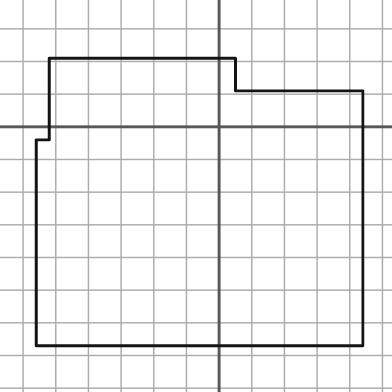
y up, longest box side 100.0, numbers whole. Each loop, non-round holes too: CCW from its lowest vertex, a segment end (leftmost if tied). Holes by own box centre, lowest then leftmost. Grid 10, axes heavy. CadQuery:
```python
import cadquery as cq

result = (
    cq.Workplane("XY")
    .moveTo(-56.0, -67.0)
    .lineTo(44.0, -67.0)
    .lineTo(44.0, 11.0)
    .lineTo(5.0, 11.0)
    .lineTo(5.0, 21.0)
    .lineTo(-52.0, 21.0)
    .lineTo(-52.0, -4.0)
    .lineTo(-56.0, -4.0)
    .close()
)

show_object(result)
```